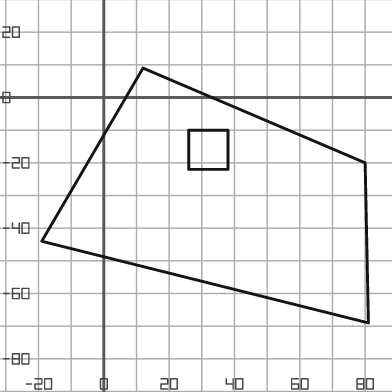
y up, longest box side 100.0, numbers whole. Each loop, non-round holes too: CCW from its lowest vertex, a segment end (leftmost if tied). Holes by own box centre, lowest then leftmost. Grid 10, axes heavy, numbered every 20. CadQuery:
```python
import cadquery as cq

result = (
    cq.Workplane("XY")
    .moveTo(81.0, -69.0)
    .lineTo(80.0, -20.0)
    .lineTo(12.0, 9.0)
    .lineTo(-19.0, -44.0)
    .close()
    .moveTo(26.0, -22.0)
    .lineTo(38.0, -22.0)
    .lineTo(38.0, -10.0)
    .lineTo(26.0, -10.0)
    .close()
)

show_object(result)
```